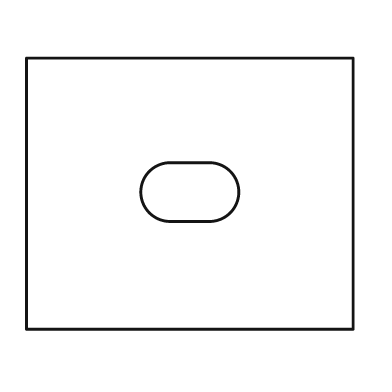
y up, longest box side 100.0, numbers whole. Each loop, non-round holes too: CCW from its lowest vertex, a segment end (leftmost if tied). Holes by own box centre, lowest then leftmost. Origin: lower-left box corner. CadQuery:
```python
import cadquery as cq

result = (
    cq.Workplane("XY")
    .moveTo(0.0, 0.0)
    .lineTo(100.0, 0.0)
    .lineTo(100.0, 83.0)
    .lineTo(0.0, 83.0)
    .close()
    .moveTo(44.0, 33.0)
    .lineTo(56.0, 33.0)
    .threePointArc((65.0, 42.0), (56.0, 51.0))
    .lineTo(44.0, 51.0)
    .threePointArc((35.0, 42.0), (44.0, 33.0))
    .close()
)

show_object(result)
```